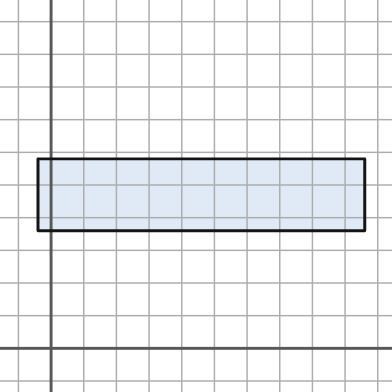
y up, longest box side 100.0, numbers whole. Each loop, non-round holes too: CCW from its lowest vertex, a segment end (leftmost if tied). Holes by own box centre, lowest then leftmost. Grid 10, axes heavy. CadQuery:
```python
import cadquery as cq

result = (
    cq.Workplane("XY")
    .moveTo(-4.0, 36.0)
    .lineTo(96.0, 36.0)
    .lineTo(96.0, 58.0)
    .lineTo(-4.0, 58.0)
    .close()
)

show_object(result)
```